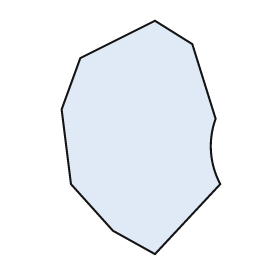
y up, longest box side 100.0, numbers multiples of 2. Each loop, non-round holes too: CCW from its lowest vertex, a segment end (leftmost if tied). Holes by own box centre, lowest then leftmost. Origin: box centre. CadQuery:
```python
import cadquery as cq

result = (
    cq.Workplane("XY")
    .moveTo(6.0, -50.0)
    .lineTo(34.0, -20.0)
    .threePointArc((30.0, -6.0), (32.0, 8.0))
    .lineTo(22.0, 40.0)
    .lineTo(6.0, 50.0)
    .lineTo(-26.0, 34.0)
    .lineTo(-34.0, 12.0)
    .lineTo(-30.0, -20.0)
    .lineTo(-12.0, -40.0)
    .close()
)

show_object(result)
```